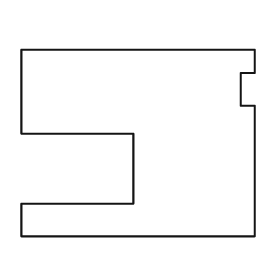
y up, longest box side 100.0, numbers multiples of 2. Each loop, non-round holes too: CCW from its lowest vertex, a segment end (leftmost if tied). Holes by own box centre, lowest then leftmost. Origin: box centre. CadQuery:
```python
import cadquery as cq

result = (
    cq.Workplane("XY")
    .moveTo(-50.0, -40.0)
    .lineTo(50.0, -40.0)
    .lineTo(50.0, 16.0)
    .lineTo(44.0, 16.0)
    .lineTo(44.0, 30.0)
    .lineTo(50.0, 30.0)
    .lineTo(50.0, 40.0)
    .lineTo(-50.0, 40.0)
    .lineTo(-50.0, 4.0)
    .lineTo(-2.0, 4.0)
    .lineTo(-2.0, -26.0)
    .lineTo(-50.0, -26.0)
    .close()
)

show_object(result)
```